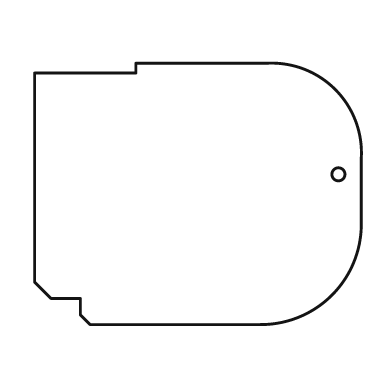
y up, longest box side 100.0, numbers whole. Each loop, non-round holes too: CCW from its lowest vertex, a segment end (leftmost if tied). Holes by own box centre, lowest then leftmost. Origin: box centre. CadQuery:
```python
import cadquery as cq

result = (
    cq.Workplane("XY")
    .moveTo(-33.0, -40.0)
    .lineTo(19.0, -40.0)
    .threePointArc((41.0, -31.0), (50.0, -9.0))
    .lineTo(50.0, 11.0)
    .threePointArc((42.0, 32.0), (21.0, 40.0))
    .lineTo(-19.0, 40.0)
    .lineTo(-19.0, 37.0)
    .lineTo(-50.0, 37.0)
    .lineTo(-50.0, -27.0)
    .lineTo(-45.0, -32.0)
    .lineTo(-36.0, -32.0)
    .lineTo(-36.0, -37.0)
    .close()
    .moveTo(43.0, 6.0)
    .circle(2.0)
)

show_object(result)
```